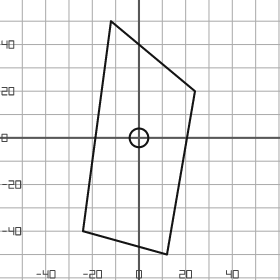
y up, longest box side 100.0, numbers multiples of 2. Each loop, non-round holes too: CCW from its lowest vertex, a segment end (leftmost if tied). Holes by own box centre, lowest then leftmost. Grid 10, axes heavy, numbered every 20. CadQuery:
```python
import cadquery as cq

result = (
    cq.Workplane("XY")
    .moveTo(12.0, -50.0)
    .lineTo(24.0, 20.0)
    .lineTo(-12.0, 50.0)
    .lineTo(-24.0, -40.0)
    .close()
    .moveTo(0.0, 0.0)
    .circle(4.0)
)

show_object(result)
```